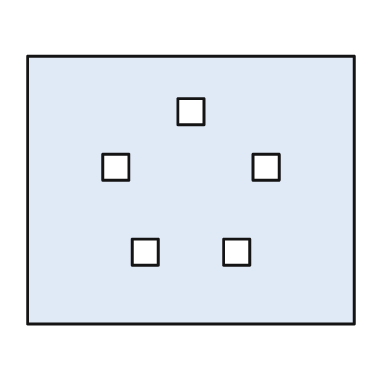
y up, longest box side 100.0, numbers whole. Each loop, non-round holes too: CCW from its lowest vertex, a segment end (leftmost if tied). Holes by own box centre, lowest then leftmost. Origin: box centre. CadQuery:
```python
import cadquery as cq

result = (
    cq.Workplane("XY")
    .moveTo(-50.0, -41.0)
    .lineTo(50.0, -41.0)
    .lineTo(50.0, 41.0)
    .lineTo(-50.0, 41.0)
    .close()
    .moveTo(-18.0, -23.0)
    .lineTo(-10.0, -23.0)
    .lineTo(-10.0, -15.0)
    .lineTo(-18.0, -15.0)
    .close()
    .moveTo(10.0, -23.0)
    .lineTo(18.0, -23.0)
    .lineTo(18.0, -15.0)
    .lineTo(10.0, -15.0)
    .close()
    .moveTo(-27.0, 3.0)
    .lineTo(-19.0, 3.0)
    .lineTo(-19.0, 11.0)
    .lineTo(-27.0, 11.0)
    .close()
    .moveTo(19.0, 3.0)
    .lineTo(27.0, 3.0)
    .lineTo(27.0, 11.0)
    .lineTo(19.0, 11.0)
    .close()
    .moveTo(-4.0, 20.0)
    .lineTo(4.0, 20.0)
    .lineTo(4.0, 28.0)
    .lineTo(-4.0, 28.0)
    .close()
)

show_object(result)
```